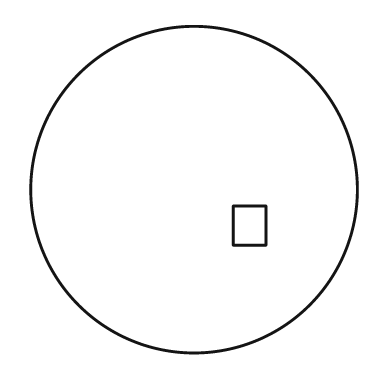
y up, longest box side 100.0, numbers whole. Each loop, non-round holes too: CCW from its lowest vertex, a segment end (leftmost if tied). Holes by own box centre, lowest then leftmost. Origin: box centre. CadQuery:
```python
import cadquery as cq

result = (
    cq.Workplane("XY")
    .moveTo(0.0, 0.0)
    .circle(50.0)
    .moveTo(12.0, -17.0)
    .lineTo(22.0, -17.0)
    .lineTo(22.0, -5.0)
    .lineTo(12.0, -5.0)
    .close()
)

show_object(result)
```